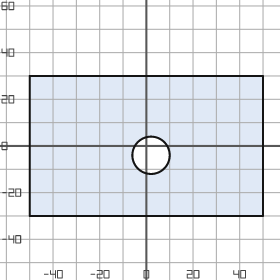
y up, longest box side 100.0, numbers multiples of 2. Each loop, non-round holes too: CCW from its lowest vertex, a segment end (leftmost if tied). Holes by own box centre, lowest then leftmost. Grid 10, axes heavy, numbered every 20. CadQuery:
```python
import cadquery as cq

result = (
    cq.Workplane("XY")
    .moveTo(-50.0, -30.0)
    .lineTo(50.0, -30.0)
    .lineTo(50.0, 30.0)
    .lineTo(-50.0, 30.0)
    .close()
    .moveTo(2.0, -4.0)
    .circle(8.0)
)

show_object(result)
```